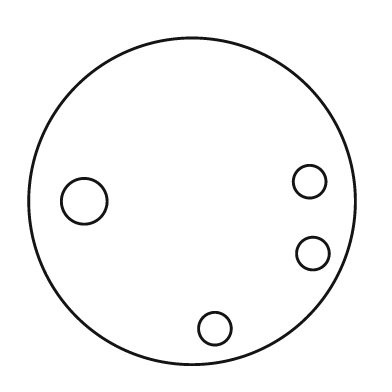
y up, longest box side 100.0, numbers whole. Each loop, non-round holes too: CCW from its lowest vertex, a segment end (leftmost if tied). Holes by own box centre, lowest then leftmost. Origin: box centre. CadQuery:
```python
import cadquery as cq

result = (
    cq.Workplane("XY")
    .moveTo(0.0, 0.0)
    .circle(50.0)
    .moveTo(7.0, -39.0)
    .circle(5.0)
    .moveTo(37.0, -16.0)
    .circle(5.0)
    .moveTo(-33.0, 0.0)
    .circle(7.0)
    .moveTo(36.0, 6.0)
    .circle(5.0)
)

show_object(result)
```